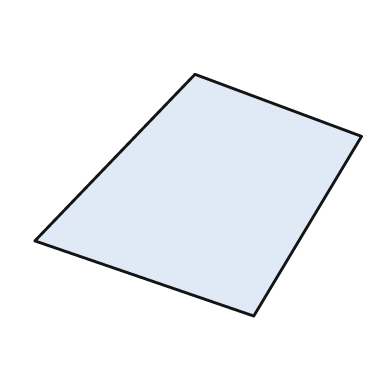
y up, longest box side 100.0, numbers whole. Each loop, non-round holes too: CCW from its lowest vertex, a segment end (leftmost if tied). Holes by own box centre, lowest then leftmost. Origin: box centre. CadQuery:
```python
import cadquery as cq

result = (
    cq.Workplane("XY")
    .moveTo(17.0, -37.0)
    .lineTo(50.0, 18.0)
    .lineTo(-1.0, 37.0)
    .lineTo(-50.0, -14.0)
    .close()
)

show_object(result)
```